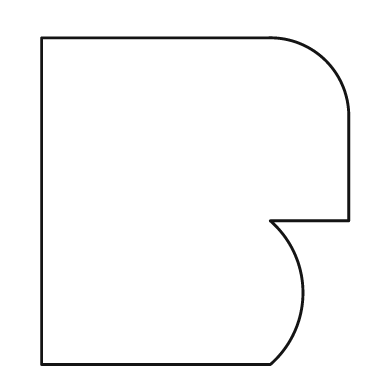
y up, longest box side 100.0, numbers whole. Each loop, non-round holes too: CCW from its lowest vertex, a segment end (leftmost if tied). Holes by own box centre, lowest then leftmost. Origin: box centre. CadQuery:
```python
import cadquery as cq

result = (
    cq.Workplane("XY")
    .moveTo(-47.0, -50.0)
    .lineTo(23.0, -50.0)
    .threePointArc((33.0, -28.0), (23.0, -6.0))
    .lineTo(47.0, -6.0)
    .lineTo(47.0, 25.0)
    .threePointArc((40.0, 43.0), (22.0, 50.0))
    .lineTo(-47.0, 50.0)
    .close()
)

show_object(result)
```